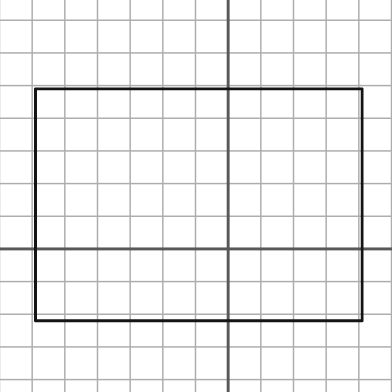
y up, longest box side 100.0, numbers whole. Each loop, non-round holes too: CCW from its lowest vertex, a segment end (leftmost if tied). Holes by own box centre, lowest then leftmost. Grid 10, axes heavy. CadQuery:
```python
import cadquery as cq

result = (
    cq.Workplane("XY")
    .moveTo(-59.0, -22.0)
    .lineTo(41.0, -22.0)
    .lineTo(41.0, 49.0)
    .lineTo(-59.0, 49.0)
    .close()
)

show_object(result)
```